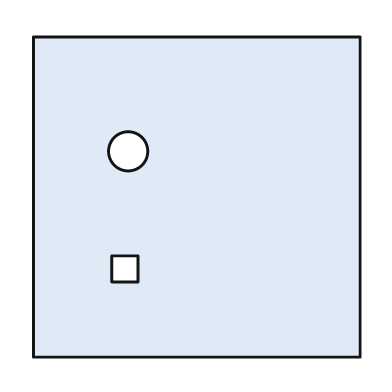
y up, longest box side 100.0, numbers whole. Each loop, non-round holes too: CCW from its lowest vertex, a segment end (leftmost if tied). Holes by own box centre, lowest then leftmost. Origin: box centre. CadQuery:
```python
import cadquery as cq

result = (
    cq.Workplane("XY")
    .moveTo(-50.0, -49.0)
    .lineTo(50.0, -49.0)
    .lineTo(50.0, 49.0)
    .lineTo(-50.0, 49.0)
    .close()
    .moveTo(-26.0, -26.0)
    .lineTo(-18.0, -26.0)
    .lineTo(-18.0, -18.0)
    .lineTo(-26.0, -18.0)
    .close()
    .moveTo(-21.0, 14.0)
    .circle(6.0)
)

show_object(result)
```